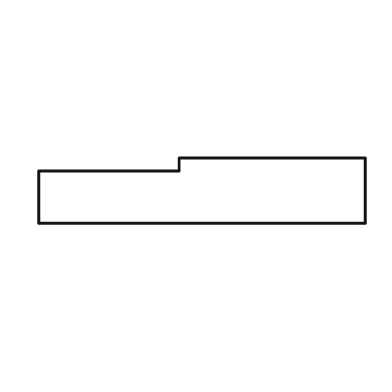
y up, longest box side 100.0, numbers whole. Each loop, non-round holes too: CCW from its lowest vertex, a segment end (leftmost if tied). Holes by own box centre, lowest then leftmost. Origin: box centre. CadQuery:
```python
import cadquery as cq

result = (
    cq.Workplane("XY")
    .moveTo(-50.0, -10.0)
    .lineTo(50.0, -10.0)
    .lineTo(50.0, 10.0)
    .lineTo(-7.0, 10.0)
    .lineTo(-7.0, 6.0)
    .lineTo(-50.0, 6.0)
    .close()
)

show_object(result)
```